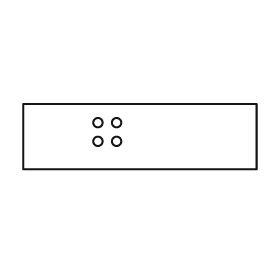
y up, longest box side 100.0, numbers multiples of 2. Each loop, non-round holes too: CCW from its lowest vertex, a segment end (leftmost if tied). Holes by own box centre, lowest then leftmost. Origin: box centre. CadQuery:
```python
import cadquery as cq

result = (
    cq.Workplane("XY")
    .moveTo(-50.0, -14.0)
    .lineTo(50.0, -14.0)
    .lineTo(50.0, 14.0)
    .lineTo(-50.0, 14.0)
    .close()
    .moveTo(-18.0, -2.0)
    .circle(2.0)
    .moveTo(-10.0, -2.0)
    .circle(2.0)
    .moveTo(-18.0, 6.0)
    .circle(2.0)
    .moveTo(-10.0, 6.0)
    .circle(2.0)
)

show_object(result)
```